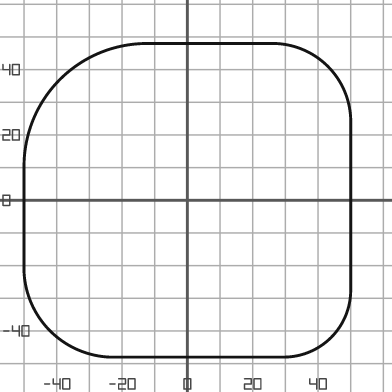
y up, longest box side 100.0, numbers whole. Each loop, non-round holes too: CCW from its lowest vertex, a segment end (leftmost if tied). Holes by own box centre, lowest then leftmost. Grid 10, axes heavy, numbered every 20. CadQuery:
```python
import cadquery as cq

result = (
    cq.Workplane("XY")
    .moveTo(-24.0, -48.0)
    .lineTo(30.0, -48.0)
    .threePointArc((44.0, -42.0), (50.0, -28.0))
    .lineTo(50.0, 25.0)
    .threePointArc((43.0, 41.0), (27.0, 48.0))
    .lineTo(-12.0, 48.0)
    .threePointArc((-39.0, 37.0), (-50.0, 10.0))
    .lineTo(-50.0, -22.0)
    .threePointArc((-42.0, -40.0), (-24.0, -48.0))
    .close()
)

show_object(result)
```